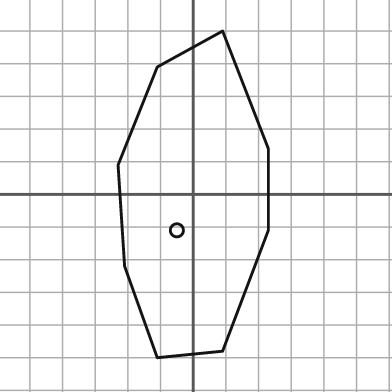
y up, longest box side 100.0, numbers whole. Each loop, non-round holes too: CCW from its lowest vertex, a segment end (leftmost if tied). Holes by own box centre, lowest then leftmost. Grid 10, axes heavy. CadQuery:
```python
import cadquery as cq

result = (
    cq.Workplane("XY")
    .moveTo(-11.0, -50.0)
    .lineTo(9.0, -48.0)
    .lineTo(23.0, -11.0)
    .lineTo(23.0, 14.0)
    .lineTo(9.0, 50.0)
    .lineTo(-11.0, 39.0)
    .lineTo(-23.0, 9.0)
    .lineTo(-21.0, -22.0)
    .close()
    .moveTo(-5.0, -11.0)
    .circle(2.0)
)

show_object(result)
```